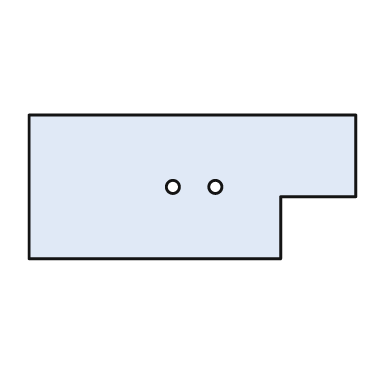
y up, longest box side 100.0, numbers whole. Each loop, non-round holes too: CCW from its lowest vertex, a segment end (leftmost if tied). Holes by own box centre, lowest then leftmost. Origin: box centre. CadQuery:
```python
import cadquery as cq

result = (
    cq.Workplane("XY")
    .moveTo(-50.0, -22.0)
    .lineTo(27.0, -22.0)
    .lineTo(27.0, -3.0)
    .lineTo(50.0, -3.0)
    .lineTo(50.0, 22.0)
    .lineTo(-50.0, 22.0)
    .close()
    .moveTo(-6.0, 0.0)
    .circle(2.0)
    .moveTo(7.0, 0.0)
    .circle(2.0)
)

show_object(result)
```